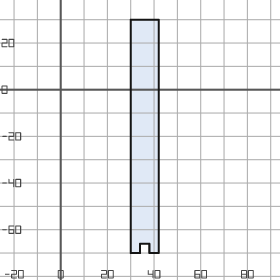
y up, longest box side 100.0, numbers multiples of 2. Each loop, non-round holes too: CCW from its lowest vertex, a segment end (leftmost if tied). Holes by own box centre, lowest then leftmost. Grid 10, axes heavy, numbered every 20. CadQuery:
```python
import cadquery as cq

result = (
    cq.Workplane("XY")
    .moveTo(30.0, -70.0)
    .lineTo(34.0, -70.0)
    .lineTo(34.0, -66.0)
    .lineTo(38.0, -66.0)
    .lineTo(38.0, -70.0)
    .lineTo(42.0, -70.0)
    .lineTo(42.0, 30.0)
    .lineTo(30.0, 30.0)
    .close()
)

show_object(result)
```